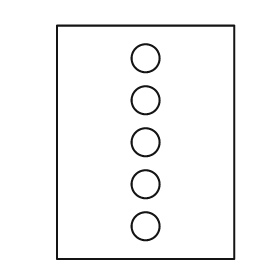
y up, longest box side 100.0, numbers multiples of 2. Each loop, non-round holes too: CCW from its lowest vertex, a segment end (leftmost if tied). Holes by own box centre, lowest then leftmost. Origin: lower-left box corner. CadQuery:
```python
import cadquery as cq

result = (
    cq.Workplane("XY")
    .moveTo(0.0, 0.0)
    .lineTo(76.0, 0.0)
    .lineTo(76.0, 100.0)
    .lineTo(0.0, 100.0)
    .close()
    .moveTo(38.0, 14.0)
    .circle(6.0)
    .moveTo(38.0, 32.0)
    .circle(6.0)
    .moveTo(38.0, 50.0)
    .circle(6.0)
    .moveTo(38.0, 68.0)
    .circle(6.0)
    .moveTo(38.0, 86.0)
    .circle(6.0)
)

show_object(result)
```